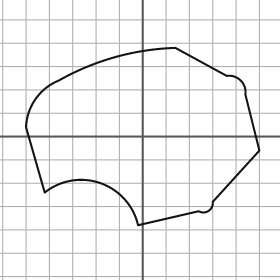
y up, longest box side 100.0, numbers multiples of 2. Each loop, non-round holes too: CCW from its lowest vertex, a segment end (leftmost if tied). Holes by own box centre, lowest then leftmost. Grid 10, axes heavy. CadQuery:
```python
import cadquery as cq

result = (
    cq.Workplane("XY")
    .moveTo(-2.0, -38.0)
    .lineTo(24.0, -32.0)
    .threePointArc((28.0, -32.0), (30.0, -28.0))
    .lineTo(50.0, -6.0)
    .lineTo(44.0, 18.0)
    .threePointArc((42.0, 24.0), (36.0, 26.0))
    .lineTo(14.0, 38.0)
    .threePointArc((-12.0, 34.0), (-36.0, 24.0))
    .threePointArc((-46.0, 16.0), (-50.0, 4.0))
    .lineTo(-42.0, -24.0)
    .threePointArc((-18.0, -20.0), (-2.0, -38.0))
    .close()
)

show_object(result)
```